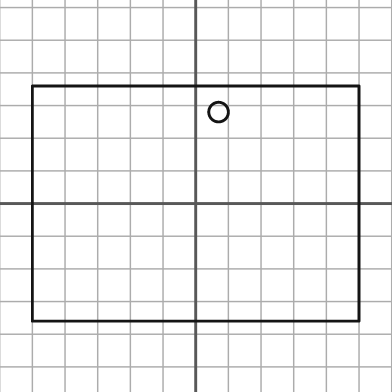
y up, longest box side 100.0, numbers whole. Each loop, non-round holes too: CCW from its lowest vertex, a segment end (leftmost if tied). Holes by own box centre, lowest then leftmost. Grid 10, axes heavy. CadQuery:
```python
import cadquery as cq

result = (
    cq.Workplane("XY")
    .moveTo(-50.0, -36.0)
    .lineTo(50.0, -36.0)
    .lineTo(50.0, 36.0)
    .lineTo(-50.0, 36.0)
    .close()
    .moveTo(7.0, 28.0)
    .circle(3.0)
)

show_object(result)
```